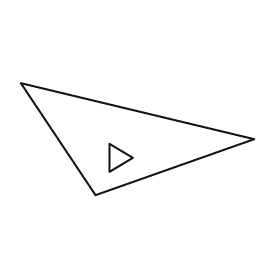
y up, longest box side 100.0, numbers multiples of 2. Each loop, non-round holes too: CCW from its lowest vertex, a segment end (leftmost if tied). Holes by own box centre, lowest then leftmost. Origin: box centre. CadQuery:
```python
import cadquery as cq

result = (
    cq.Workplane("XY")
    .moveTo(-18.0, -24.0)
    .lineTo(50.0, 0.0)
    .lineTo(-50.0, 24.0)
    .close()
    .moveTo(-12.0, -14.0)
    .lineTo(-2.0, -8.0)
    .lineTo(-12.0, -2.0)
    .close()
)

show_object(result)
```